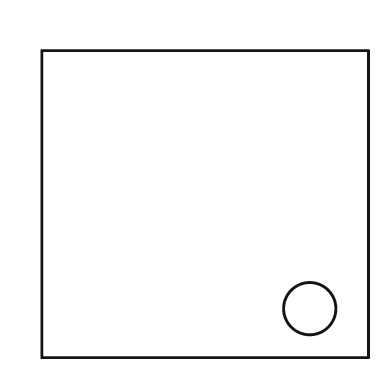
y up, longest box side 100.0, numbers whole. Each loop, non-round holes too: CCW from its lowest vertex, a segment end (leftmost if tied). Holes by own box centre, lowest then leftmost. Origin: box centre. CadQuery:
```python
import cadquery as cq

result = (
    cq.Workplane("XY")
    .moveTo(-50.0, -47.0)
    .lineTo(50.0, -47.0)
    .lineTo(50.0, 47.0)
    .lineTo(-50.0, 47.0)
    .close()
    .moveTo(32.0, -32.0)
    .circle(8.0)
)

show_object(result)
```